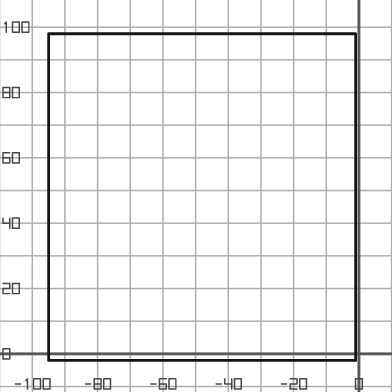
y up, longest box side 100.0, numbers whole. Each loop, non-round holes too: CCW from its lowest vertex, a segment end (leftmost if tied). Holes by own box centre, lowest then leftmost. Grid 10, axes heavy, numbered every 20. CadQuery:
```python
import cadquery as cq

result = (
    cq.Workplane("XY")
    .moveTo(-95.0, -2.0)
    .lineTo(-1.0, -2.0)
    .lineTo(-1.0, 98.0)
    .lineTo(-95.0, 98.0)
    .close()
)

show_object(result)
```